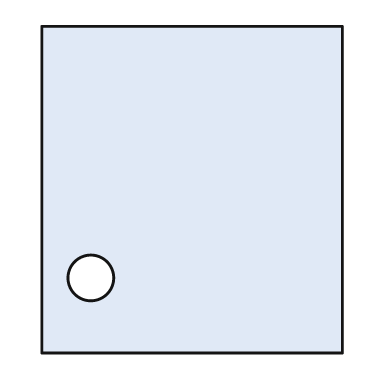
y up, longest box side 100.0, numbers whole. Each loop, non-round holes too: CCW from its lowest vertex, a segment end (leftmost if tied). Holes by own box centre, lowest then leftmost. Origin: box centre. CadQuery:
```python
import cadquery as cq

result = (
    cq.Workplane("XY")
    .moveTo(-46.0, -50.0)
    .lineTo(46.0, -50.0)
    .lineTo(46.0, 50.0)
    .lineTo(-46.0, 50.0)
    .close()
    .moveTo(-31.0, -27.0)
    .circle(7.0)
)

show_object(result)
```